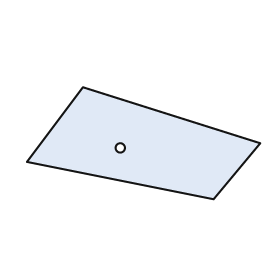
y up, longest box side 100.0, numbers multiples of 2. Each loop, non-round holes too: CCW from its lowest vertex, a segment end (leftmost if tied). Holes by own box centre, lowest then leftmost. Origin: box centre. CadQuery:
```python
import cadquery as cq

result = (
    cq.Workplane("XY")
    .moveTo(30.0, -24.0)
    .lineTo(50.0, 0.0)
    .lineTo(-26.0, 24.0)
    .lineTo(-50.0, -8.0)
    .close()
    .moveTo(-10.0, -2.0)
    .circle(2.0)
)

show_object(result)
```